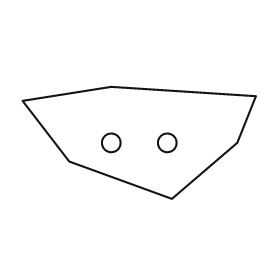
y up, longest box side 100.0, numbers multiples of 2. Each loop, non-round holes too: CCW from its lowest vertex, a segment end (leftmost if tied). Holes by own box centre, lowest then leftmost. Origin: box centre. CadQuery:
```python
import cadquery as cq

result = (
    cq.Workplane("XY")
    .moveTo(14.0, -24.0)
    .lineTo(42.0, 0.0)
    .lineTo(50.0, 20.0)
    .lineTo(-12.0, 24.0)
    .lineTo(-50.0, 18.0)
    .lineTo(-30.0, -8.0)
    .close()
    .moveTo(-12.0, 0.0)
    .circle(4.0)
    .moveTo(12.0, 0.0)
    .circle(4.0)
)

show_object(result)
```